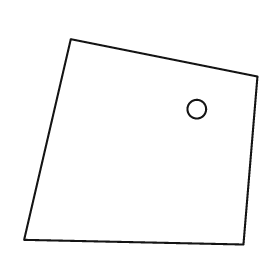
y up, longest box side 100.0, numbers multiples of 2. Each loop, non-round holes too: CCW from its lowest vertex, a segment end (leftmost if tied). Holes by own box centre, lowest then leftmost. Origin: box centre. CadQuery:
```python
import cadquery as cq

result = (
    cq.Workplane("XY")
    .moveTo(44.0, -44.0)
    .lineTo(50.0, 28.0)
    .lineTo(-30.0, 44.0)
    .lineTo(-50.0, -42.0)
    .close()
    .moveTo(24.0, 14.0)
    .circle(4.0)
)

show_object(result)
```